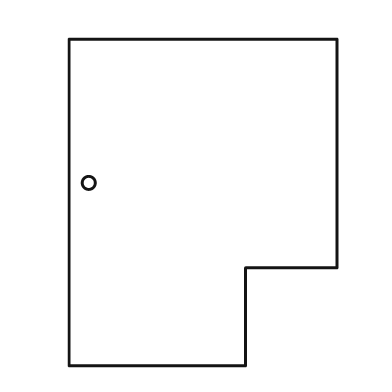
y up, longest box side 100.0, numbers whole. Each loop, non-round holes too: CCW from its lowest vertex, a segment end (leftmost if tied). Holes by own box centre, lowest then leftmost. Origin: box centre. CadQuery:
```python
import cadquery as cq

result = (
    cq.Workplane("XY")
    .moveTo(-41.0, -50.0)
    .lineTo(13.0, -50.0)
    .lineTo(13.0, -20.0)
    .lineTo(41.0, -20.0)
    .lineTo(41.0, 50.0)
    .lineTo(-41.0, 50.0)
    .close()
    .moveTo(-35.0, 6.0)
    .circle(2.0)
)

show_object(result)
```